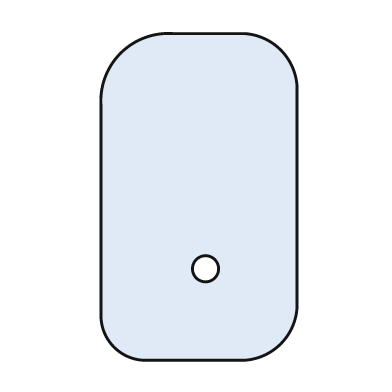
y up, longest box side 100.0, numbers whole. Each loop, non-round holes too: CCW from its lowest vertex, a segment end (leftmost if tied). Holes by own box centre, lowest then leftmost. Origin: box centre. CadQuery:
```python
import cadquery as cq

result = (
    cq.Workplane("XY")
    .moveTo(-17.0, -50.0)
    .lineTo(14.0, -50.0)
    .threePointArc((25.0, -45.0), (30.0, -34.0))
    .lineTo(30.0, 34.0)
    .threePointArc((25.0, 45.0), (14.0, 50.0))
    .lineTo(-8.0, 50.0)
    .threePointArc((-24.0, 44.0), (-30.0, 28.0))
    .lineTo(-30.0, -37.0)
    .threePointArc((-26.0, -46.0), (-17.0, -50.0))
    .close()
    .moveTo(2.0, -22.0)
    .circle(4.0)
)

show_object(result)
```